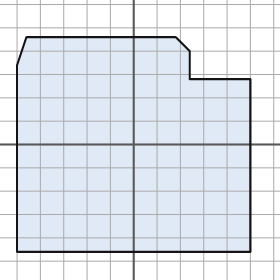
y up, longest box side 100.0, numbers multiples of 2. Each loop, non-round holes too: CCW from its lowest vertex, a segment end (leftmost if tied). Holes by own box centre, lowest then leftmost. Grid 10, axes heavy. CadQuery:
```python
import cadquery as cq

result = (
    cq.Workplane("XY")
    .moveTo(-50.0, -46.0)
    .lineTo(50.0, -46.0)
    .lineTo(50.0, 28.0)
    .lineTo(24.0, 28.0)
    .lineTo(24.0, 40.0)
    .lineTo(18.0, 46.0)
    .lineTo(-46.0, 46.0)
    .lineTo(-50.0, 34.0)
    .close()
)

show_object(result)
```